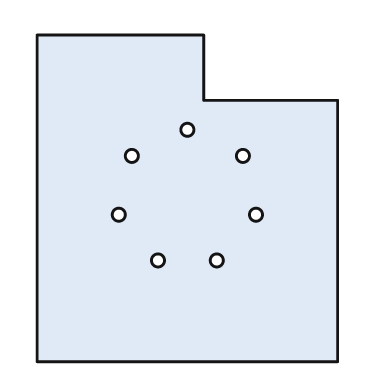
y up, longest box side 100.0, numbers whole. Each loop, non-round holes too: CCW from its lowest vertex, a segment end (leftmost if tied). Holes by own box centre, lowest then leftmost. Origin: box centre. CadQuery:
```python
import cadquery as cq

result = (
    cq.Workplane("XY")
    .moveTo(-46.0, -50.0)
    .lineTo(46.0, -50.0)
    .lineTo(46.0, 30.0)
    .lineTo(5.0, 30.0)
    .lineTo(5.0, 50.0)
    .lineTo(-46.0, 50.0)
    .close()
    .moveTo(-9.0, -19.0)
    .circle(2.0)
    .moveTo(9.0, -19.0)
    .circle(2.0)
    .moveTo(-21.0, -5.0)
    .circle(2.0)
    .moveTo(21.0, -5.0)
    .circle(2.0)
    .moveTo(-17.0, 13.0)
    .circle(2.0)
    .moveTo(17.0, 13.0)
    .circle(2.0)
    .moveTo(0.0, 21.0)
    .circle(2.0)
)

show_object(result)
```